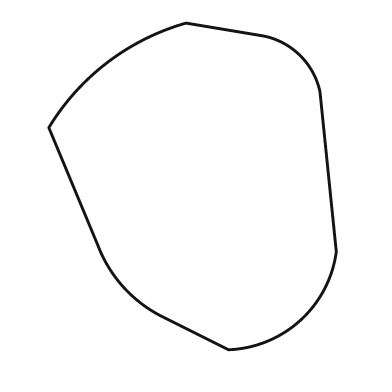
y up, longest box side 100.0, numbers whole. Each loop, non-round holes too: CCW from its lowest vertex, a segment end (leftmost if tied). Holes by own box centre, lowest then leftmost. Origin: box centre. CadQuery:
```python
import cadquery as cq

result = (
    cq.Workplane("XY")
    .moveTo(11.0, -50.0)
    .threePointArc((33.0, -41.0), (44.0, -20.0))
    .lineTo(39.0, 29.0)
    .threePointArc((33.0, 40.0), (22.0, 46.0))
    .lineTo(-2.0, 50.0)
    .threePointArc((-26.0, 38.0), (-44.0, 18.0))
    .lineTo(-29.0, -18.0)
    .threePointArc((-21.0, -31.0), (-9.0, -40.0))
    .close()
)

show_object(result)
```